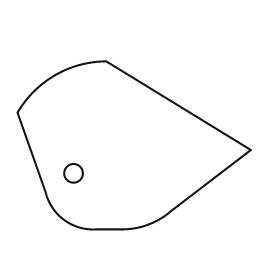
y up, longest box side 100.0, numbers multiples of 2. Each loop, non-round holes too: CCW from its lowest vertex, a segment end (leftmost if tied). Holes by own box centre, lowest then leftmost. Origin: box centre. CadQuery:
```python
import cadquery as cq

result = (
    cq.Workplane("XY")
    .moveTo(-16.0, -36.0)
    .lineTo(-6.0, -36.0)
    .threePointArc((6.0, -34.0), (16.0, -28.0))
    .lineTo(50.0, -2.0)
    .lineTo(-12.0, 36.0)
    .threePointArc((-34.0, 30.0), (-50.0, 14.0))
    .lineTo(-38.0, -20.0)
    .threePointArc((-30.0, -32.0), (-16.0, -36.0))
    .close()
    .moveTo(-26.0, -12.0)
    .circle(4.0)
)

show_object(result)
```